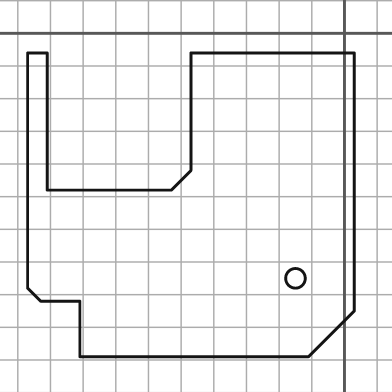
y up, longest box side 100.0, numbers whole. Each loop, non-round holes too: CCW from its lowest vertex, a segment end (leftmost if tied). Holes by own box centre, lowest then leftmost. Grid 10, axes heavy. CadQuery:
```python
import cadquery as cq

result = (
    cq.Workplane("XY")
    .moveTo(-81.0, -99.0)
    .lineTo(-11.0, -99.0)
    .lineTo(3.0, -85.0)
    .lineTo(3.0, -6.0)
    .lineTo(-47.0, -6.0)
    .lineTo(-47.0, -42.0)
    .lineTo(-53.0, -48.0)
    .lineTo(-91.0, -48.0)
    .lineTo(-91.0, -6.0)
    .lineTo(-97.0, -6.0)
    .lineTo(-97.0, -78.0)
    .lineTo(-93.0, -82.0)
    .lineTo(-81.0, -82.0)
    .close()
    .moveTo(-15.0, -75.0)
    .circle(3.0)
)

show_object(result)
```